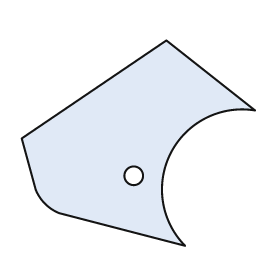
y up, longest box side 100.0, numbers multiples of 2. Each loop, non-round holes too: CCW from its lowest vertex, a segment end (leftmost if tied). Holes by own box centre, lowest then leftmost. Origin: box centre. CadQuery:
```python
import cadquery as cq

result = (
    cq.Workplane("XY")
    .moveTo(20.0, -44.0)
    .threePointArc((14.0, -4.0), (50.0, 14.0))
    .lineTo(12.0, 44.0)
    .lineTo(-50.0, 2.0)
    .lineTo(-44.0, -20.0)
    .threePointArc((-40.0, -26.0), (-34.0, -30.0))
    .close()
    .moveTo(-2.0, -14.0)
    .circle(4.0)
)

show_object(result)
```